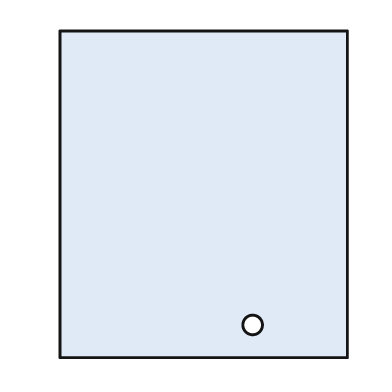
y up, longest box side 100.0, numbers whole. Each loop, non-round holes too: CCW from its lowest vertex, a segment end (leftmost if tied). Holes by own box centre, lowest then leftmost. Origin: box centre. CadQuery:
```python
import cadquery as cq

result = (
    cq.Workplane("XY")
    .moveTo(-44.0, -50.0)
    .lineTo(44.0, -50.0)
    .lineTo(44.0, 50.0)
    .lineTo(-44.0, 50.0)
    .close()
    .moveTo(15.0, -40.0)
    .circle(3.0)
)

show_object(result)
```